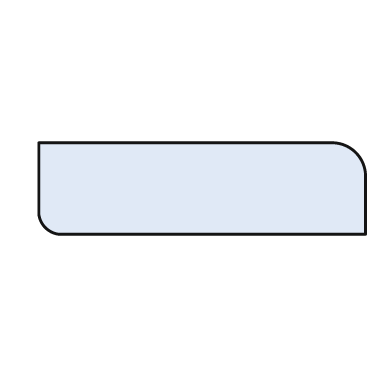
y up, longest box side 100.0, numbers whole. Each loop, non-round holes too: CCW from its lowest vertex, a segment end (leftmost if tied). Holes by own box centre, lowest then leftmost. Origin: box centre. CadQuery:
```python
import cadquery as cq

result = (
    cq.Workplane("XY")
    .moveTo(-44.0, -14.0)
    .lineTo(50.0, -14.0)
    .lineTo(50.0, 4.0)
    .threePointArc((47.0, 11.0), (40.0, 14.0))
    .lineTo(-50.0, 14.0)
    .lineTo(-50.0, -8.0)
    .threePointArc((-48.0, -12.0), (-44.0, -14.0))
    .close()
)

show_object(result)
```